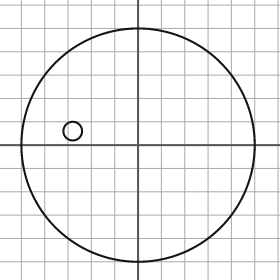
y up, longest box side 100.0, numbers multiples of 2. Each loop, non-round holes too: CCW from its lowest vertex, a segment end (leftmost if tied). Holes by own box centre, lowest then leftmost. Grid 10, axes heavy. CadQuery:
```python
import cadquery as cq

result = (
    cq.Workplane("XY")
    .moveTo(0.0, 0.0)
    .circle(50.0)
    .moveTo(-28.0, 6.0)
    .circle(4.0)
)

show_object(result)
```